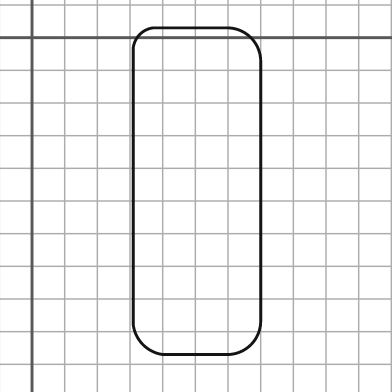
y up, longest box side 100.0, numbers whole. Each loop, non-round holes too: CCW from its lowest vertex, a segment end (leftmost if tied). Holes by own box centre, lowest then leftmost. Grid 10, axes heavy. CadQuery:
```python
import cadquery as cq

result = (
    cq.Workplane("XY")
    .moveTo(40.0, -97.0)
    .lineTo(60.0, -97.0)
    .threePointArc((67.0, -94.0), (70.0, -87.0))
    .lineTo(70.0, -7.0)
    .threePointArc((67.0, 0.0), (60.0, 3.0))
    .lineTo(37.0, 3.0)
    .threePointArc((33.0, 1.0), (31.0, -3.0))
    .lineTo(31.0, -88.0)
    .threePointArc((34.0, -94.0), (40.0, -97.0))
    .close()
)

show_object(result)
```